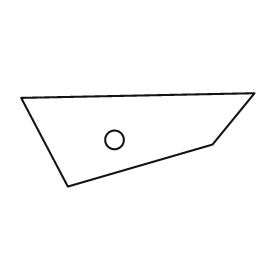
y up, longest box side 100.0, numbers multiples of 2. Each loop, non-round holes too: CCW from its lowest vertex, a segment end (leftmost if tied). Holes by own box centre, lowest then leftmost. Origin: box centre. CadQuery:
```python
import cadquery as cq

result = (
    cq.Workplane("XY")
    .moveTo(-30.0, -20.0)
    .lineTo(32.0, -2.0)
    .lineTo(50.0, 20.0)
    .lineTo(-50.0, 18.0)
    .close()
    .moveTo(-10.0, 0.0)
    .circle(4.0)
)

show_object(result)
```